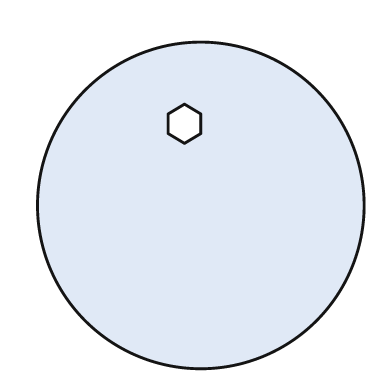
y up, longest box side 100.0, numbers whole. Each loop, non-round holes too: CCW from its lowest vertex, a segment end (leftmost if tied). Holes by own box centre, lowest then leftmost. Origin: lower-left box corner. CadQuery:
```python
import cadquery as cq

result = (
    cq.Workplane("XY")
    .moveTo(50.0, 50.0)
    .circle(50.0)
    .moveTo(45.0, 69.0)
    .lineTo(50.0, 72.0)
    .lineTo(50.0, 78.0)
    .lineTo(45.0, 81.0)
    .lineTo(40.0, 78.0)
    .lineTo(40.0, 72.0)
    .close()
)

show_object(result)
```